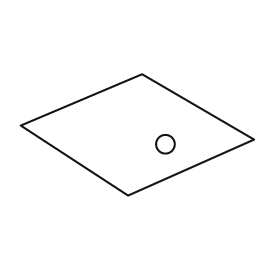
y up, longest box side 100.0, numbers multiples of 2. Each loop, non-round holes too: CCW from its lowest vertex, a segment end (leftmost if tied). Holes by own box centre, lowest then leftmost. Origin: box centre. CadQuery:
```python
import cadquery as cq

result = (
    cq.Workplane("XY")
    .moveTo(-4.0, -26.0)
    .lineTo(50.0, -2.0)
    .lineTo(2.0, 26.0)
    .lineTo(-50.0, 4.0)
    .close()
    .moveTo(12.0, -4.0)
    .circle(4.0)
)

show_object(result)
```